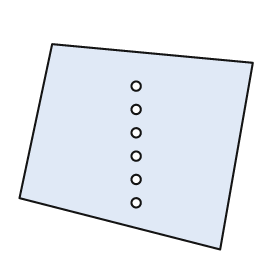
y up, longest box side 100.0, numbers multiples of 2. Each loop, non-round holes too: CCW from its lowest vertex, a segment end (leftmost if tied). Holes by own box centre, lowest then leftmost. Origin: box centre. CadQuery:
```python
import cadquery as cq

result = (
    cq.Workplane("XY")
    .moveTo(36.0, -44.0)
    .lineTo(50.0, 36.0)
    .lineTo(-36.0, 44.0)
    .lineTo(-50.0, -22.0)
    .close()
    .moveTo(0.0, -24.0)
    .circle(2.0)
    .moveTo(0.0, -14.0)
    .circle(2.0)
    .moveTo(0.0, -4.0)
    .circle(2.0)
    .moveTo(0.0, 6.0)
    .circle(2.0)
    .moveTo(0.0, 16.0)
    .circle(2.0)
    .moveTo(0.0, 26.0)
    .circle(2.0)
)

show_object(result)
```